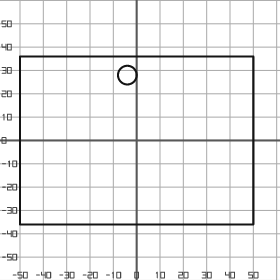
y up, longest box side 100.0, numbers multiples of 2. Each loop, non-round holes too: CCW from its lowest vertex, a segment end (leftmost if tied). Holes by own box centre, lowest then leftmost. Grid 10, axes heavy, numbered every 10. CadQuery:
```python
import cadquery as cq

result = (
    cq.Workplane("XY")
    .moveTo(-50.0, -36.0)
    .lineTo(50.0, -36.0)
    .lineTo(50.0, 36.0)
    .lineTo(-50.0, 36.0)
    .close()
    .moveTo(-4.0, 28.0)
    .circle(4.0)
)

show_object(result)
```